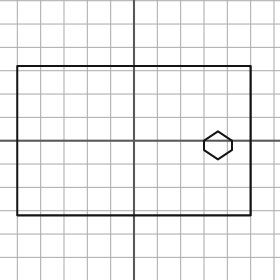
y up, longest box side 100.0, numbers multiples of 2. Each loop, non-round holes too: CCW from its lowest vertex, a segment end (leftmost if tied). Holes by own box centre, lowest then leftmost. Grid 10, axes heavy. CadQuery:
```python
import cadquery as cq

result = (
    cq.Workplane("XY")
    .moveTo(-50.0, -32.0)
    .lineTo(50.0, -32.0)
    .lineTo(50.0, 32.0)
    .lineTo(-50.0, 32.0)
    .close()
    .moveTo(36.0, -8.0)
    .lineTo(42.0, -4.0)
    .lineTo(42.0, 0.0)
    .lineTo(36.0, 4.0)
    .lineTo(30.0, 0.0)
    .lineTo(30.0, -4.0)
    .close()
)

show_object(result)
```